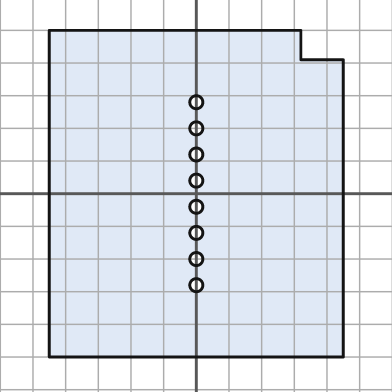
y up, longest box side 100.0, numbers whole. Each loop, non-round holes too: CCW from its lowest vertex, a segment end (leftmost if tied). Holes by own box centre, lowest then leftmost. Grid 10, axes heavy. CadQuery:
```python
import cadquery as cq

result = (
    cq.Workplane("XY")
    .moveTo(-45.0, -50.0)
    .lineTo(45.0, -50.0)
    .lineTo(45.0, 41.0)
    .lineTo(32.0, 41.0)
    .lineTo(32.0, 50.0)
    .lineTo(-45.0, 50.0)
    .close()
    .moveTo(0.0, -28.0)
    .circle(2.0)
    .moveTo(0.0, -20.0)
    .circle(2.0)
    .moveTo(0.0, -12.0)
    .circle(2.0)
    .moveTo(0.0, -4.0)
    .circle(2.0)
    .moveTo(0.0, 4.0)
    .circle(2.0)
    .moveTo(0.0, 12.0)
    .circle(2.0)
    .moveTo(0.0, 20.0)
    .circle(2.0)
    .moveTo(0.0, 28.0)
    .circle(2.0)
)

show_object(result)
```